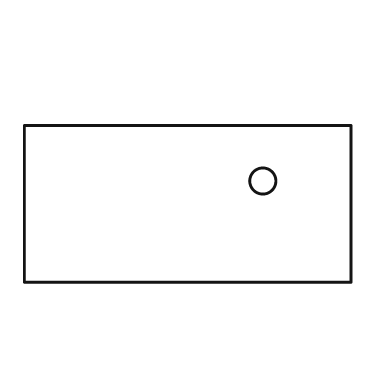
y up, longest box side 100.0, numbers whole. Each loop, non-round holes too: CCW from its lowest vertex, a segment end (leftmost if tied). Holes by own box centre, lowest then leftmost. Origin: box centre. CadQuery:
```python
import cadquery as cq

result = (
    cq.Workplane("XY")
    .moveTo(-50.0, -24.0)
    .lineTo(50.0, -24.0)
    .lineTo(50.0, 24.0)
    .lineTo(-50.0, 24.0)
    .close()
    .moveTo(23.0, 7.0)
    .circle(4.0)
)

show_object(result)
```